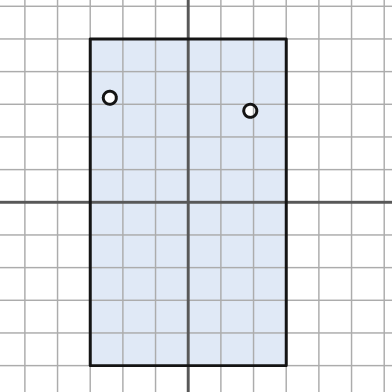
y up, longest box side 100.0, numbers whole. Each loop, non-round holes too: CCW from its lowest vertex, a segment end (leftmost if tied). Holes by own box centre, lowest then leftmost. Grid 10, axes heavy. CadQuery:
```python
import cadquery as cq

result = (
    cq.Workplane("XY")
    .moveTo(-30.0, -50.0)
    .lineTo(30.0, -50.0)
    .lineTo(30.0, 50.0)
    .lineTo(-30.0, 50.0)
    .close()
    .moveTo(19.0, 28.0)
    .circle(2.0)
    .moveTo(-24.0, 32.0)
    .circle(2.0)
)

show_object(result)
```